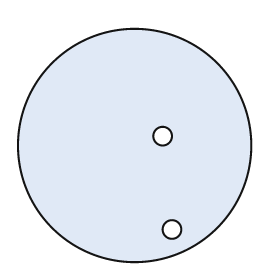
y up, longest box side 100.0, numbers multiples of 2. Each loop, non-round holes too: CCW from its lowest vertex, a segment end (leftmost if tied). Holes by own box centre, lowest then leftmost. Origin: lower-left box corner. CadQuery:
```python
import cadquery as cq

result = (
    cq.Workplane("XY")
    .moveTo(50.0, 50.0)
    .circle(50.0)
    .moveTo(66.0, 14.0)
    .circle(4.0)
    .moveTo(62.0, 54.0)
    .circle(4.0)
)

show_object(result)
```